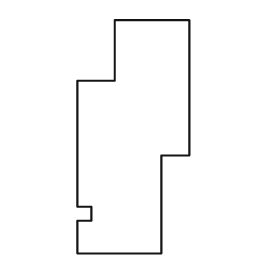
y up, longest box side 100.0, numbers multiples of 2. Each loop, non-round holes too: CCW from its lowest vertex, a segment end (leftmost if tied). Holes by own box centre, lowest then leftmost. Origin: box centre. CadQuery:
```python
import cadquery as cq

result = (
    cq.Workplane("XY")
    .moveTo(-24.0, -50.0)
    .lineTo(12.0, -50.0)
    .lineTo(12.0, -8.0)
    .lineTo(24.0, -8.0)
    .lineTo(24.0, 50.0)
    .lineTo(-8.0, 50.0)
    .lineTo(-8.0, 24.0)
    .lineTo(-24.0, 24.0)
    .lineTo(-24.0, -30.0)
    .lineTo(-18.0, -30.0)
    .lineTo(-18.0, -36.0)
    .lineTo(-24.0, -36.0)
    .close()
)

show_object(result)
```